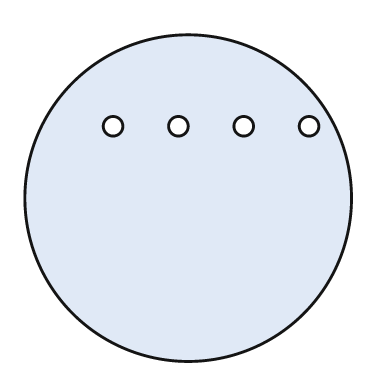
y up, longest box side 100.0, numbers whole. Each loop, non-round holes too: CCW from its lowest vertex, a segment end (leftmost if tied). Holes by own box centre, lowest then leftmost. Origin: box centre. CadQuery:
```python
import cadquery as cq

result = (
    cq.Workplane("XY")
    .moveTo(0.0, 0.0)
    .circle(50.0)
    .moveTo(-23.0, 22.0)
    .circle(3.0)
    .moveTo(-3.0, 22.0)
    .circle(3.0)
    .moveTo(17.0, 22.0)
    .circle(3.0)
    .moveTo(37.0, 22.0)
    .circle(3.0)
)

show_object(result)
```